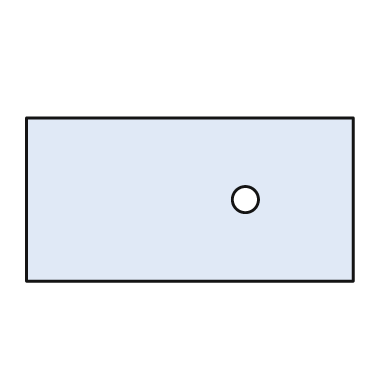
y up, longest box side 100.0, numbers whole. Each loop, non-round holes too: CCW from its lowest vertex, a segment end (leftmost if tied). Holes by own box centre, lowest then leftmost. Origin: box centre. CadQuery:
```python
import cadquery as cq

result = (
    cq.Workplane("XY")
    .moveTo(-50.0, -25.0)
    .lineTo(50.0, -25.0)
    .lineTo(50.0, 25.0)
    .lineTo(-50.0, 25.0)
    .close()
    .moveTo(17.0, 0.0)
    .circle(4.0)
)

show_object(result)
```